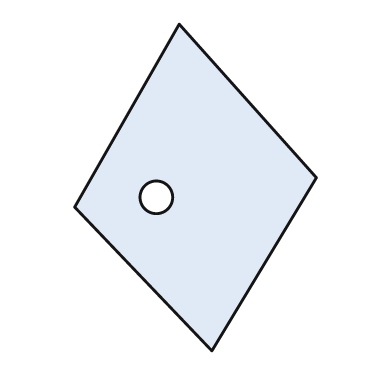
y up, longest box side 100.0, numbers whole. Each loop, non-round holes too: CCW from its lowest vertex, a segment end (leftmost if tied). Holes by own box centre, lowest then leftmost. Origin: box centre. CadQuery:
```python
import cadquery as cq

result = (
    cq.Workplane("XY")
    .moveTo(5.0, -50.0)
    .lineTo(37.0, 3.0)
    .lineTo(-5.0, 50.0)
    .lineTo(-37.0, -6.0)
    .close()
    .moveTo(-12.0, -3.0)
    .circle(5.0)
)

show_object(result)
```